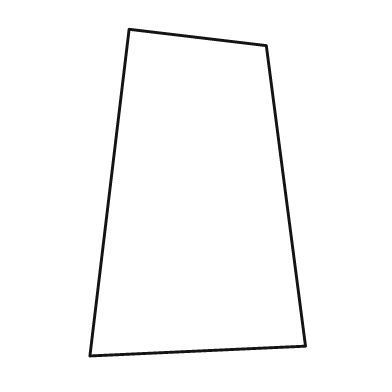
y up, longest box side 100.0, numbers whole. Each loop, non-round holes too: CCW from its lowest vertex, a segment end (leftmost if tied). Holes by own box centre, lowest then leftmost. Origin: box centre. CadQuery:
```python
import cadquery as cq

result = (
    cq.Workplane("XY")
    .moveTo(-33.0, -50.0)
    .lineTo(33.0, -47.0)
    .lineTo(21.0, 45.0)
    .lineTo(-21.0, 50.0)
    .close()
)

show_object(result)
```